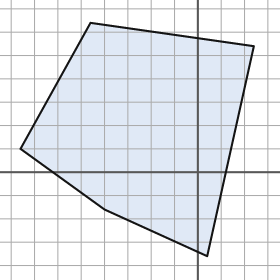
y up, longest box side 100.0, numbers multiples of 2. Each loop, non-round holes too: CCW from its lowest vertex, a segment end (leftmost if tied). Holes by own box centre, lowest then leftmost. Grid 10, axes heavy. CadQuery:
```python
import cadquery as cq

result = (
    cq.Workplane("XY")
    .moveTo(4.0, -36.0)
    .lineTo(24.0, 54.0)
    .lineTo(-46.0, 64.0)
    .lineTo(-76.0, 10.0)
    .lineTo(-40.0, -16.0)
    .close()
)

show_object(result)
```